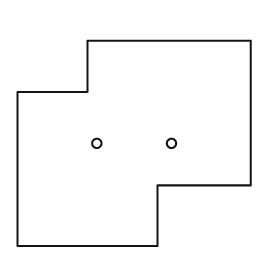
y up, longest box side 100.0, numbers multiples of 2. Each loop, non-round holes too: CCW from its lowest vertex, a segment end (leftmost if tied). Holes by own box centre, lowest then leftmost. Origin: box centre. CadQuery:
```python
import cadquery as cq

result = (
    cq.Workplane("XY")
    .moveTo(-50.0, -44.0)
    .lineTo(10.0, -44.0)
    .lineTo(10.0, -18.0)
    .lineTo(50.0, -18.0)
    .lineTo(50.0, 44.0)
    .lineTo(-20.0, 44.0)
    .lineTo(-20.0, 22.0)
    .lineTo(-50.0, 22.0)
    .close()
    .moveTo(-16.0, 0.0)
    .circle(2.0)
    .moveTo(16.0, 0.0)
    .circle(2.0)
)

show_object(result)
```